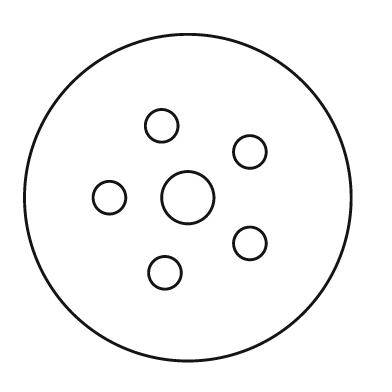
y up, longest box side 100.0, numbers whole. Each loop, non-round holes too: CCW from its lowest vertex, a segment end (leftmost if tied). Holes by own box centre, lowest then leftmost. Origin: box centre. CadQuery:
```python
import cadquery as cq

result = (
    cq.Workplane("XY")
    .moveTo(0.0, 0.0)
    .circle(50.0)
    .moveTo(-7.0, -23.0)
    .circle(5.0)
    .moveTo(19.0, -14.0)
    .circle(5.0)
    .moveTo(-24.0, 0.0)
    .circle(5.0)
    .moveTo(0.0, 0.0)
    .circle(8.0)
    .moveTo(19.0, 14.0)
    .circle(5.0)
    .moveTo(-8.0, 22.0)
    .circle(5.0)
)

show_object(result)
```